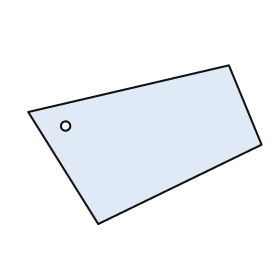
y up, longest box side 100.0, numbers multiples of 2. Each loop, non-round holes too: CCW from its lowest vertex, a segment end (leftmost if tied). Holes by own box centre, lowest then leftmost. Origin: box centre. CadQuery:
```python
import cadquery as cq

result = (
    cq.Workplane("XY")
    .moveTo(-20.0, -34.0)
    .lineTo(50.0, 0.0)
    .lineTo(36.0, 34.0)
    .lineTo(-50.0, 14.0)
    .close()
    .moveTo(-34.0, 8.0)
    .circle(2.0)
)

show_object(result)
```